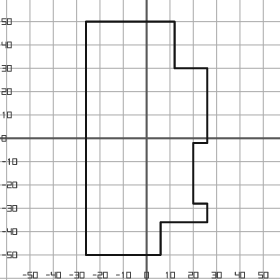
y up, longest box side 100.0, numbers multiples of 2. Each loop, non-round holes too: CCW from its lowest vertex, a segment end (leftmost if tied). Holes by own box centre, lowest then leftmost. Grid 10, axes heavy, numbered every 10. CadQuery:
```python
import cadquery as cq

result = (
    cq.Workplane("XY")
    .moveTo(-26.0, -50.0)
    .lineTo(6.0, -50.0)
    .lineTo(6.0, -36.0)
    .lineTo(26.0, -36.0)
    .lineTo(26.0, -28.0)
    .lineTo(20.0, -28.0)
    .lineTo(20.0, -2.0)
    .lineTo(26.0, -2.0)
    .lineTo(26.0, 30.0)
    .lineTo(12.0, 30.0)
    .lineTo(12.0, 50.0)
    .lineTo(-26.0, 50.0)
    .close()
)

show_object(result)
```